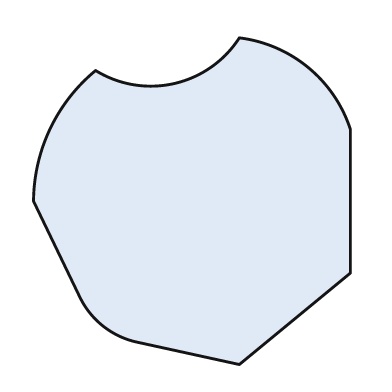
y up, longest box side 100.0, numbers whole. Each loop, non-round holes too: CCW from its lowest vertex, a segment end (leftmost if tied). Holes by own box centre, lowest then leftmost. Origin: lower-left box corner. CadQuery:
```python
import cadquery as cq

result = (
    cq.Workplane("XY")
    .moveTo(63.0, 0.0)
    .lineTo(97.0, 28.0)
    .lineTo(97.0, 72.0)
    .threePointArc((84.0, 91.0), (63.0, 100.0))
    .threePointArc((43.0, 86.0), (19.0, 90.0))
    .threePointArc((5.0, 72.0), (0.0, 50.0))
    .lineTo(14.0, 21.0)
    .threePointArc((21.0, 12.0), (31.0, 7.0))
    .close()
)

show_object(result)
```